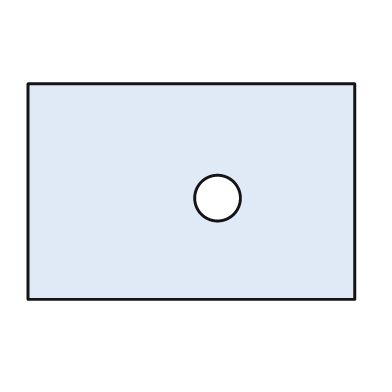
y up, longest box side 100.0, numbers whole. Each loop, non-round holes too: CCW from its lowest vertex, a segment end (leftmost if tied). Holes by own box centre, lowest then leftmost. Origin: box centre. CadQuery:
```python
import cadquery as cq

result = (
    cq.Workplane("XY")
    .moveTo(-50.0, -33.0)
    .lineTo(50.0, -33.0)
    .lineTo(50.0, 33.0)
    .lineTo(-50.0, 33.0)
    .close()
    .moveTo(8.0, -2.0)
    .circle(7.0)
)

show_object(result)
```